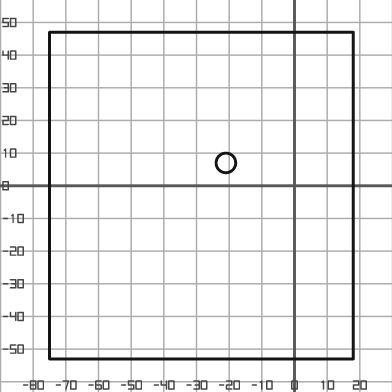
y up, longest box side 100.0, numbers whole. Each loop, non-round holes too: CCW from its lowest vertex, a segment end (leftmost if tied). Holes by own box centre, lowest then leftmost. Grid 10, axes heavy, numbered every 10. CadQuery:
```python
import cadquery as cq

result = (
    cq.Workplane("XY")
    .moveTo(-75.0, -53.0)
    .lineTo(18.0, -53.0)
    .lineTo(18.0, 47.0)
    .lineTo(-75.0, 47.0)
    .close()
    .moveTo(-21.0, 7.0)
    .circle(3.0)
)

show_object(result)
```